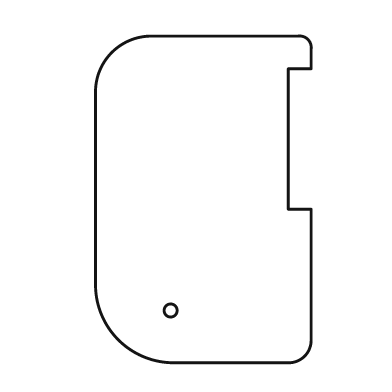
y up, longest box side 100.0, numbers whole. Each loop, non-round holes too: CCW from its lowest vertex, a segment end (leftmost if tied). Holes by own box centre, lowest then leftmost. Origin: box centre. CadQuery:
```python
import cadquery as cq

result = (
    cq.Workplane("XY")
    .moveTo(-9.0, -50.0)
    .lineTo(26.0, -50.0)
    .threePointArc((31.0, -48.0), (33.0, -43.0))
    .lineTo(33.0, -3.0)
    .lineTo(26.0, -3.0)
    .lineTo(26.0, 40.0)
    .lineTo(33.0, 40.0)
    .lineTo(33.0, 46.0)
    .threePointArc((32.0, 49.0), (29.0, 50.0))
    .lineTo(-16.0, 50.0)
    .threePointArc((-28.0, 45.0), (-33.0, 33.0))
    .lineTo(-33.0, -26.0)
    .threePointArc((-26.0, -43.0), (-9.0, -50.0))
    .close()
    .moveTo(-10.0, -34.0)
    .circle(2.0)
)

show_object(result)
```